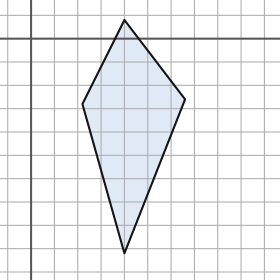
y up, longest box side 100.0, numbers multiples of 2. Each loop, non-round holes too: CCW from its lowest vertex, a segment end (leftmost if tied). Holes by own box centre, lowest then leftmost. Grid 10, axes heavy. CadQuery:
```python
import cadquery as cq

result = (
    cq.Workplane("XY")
    .moveTo(40.0, -92.0)
    .lineTo(66.0, -26.0)
    .lineTo(40.0, 8.0)
    .lineTo(22.0, -28.0)
    .close()
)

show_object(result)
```